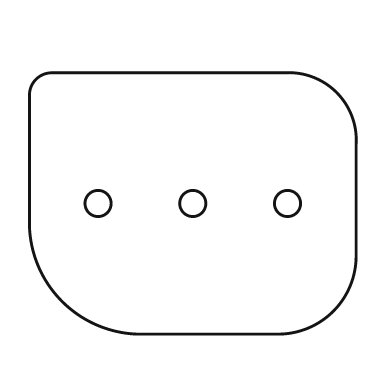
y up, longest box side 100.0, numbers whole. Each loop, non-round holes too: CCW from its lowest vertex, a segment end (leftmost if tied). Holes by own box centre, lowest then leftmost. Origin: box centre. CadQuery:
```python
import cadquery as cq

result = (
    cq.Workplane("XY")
    .moveTo(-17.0, -40.0)
    .lineTo(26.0, -40.0)
    .threePointArc((43.0, -33.0), (50.0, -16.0))
    .lineTo(50.0, 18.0)
    .threePointArc((44.0, 34.0), (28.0, 40.0))
    .lineTo(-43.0, 40.0)
    .threePointArc((-48.0, 38.0), (-50.0, 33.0))
    .lineTo(-50.0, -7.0)
    .threePointArc((-40.0, -30.0), (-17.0, -40.0))
    .close()
    .moveTo(-29.0, 0.0)
    .circle(4.0)
    .moveTo(0.0, 0.0)
    .circle(4.0)
    .moveTo(29.0, 0.0)
    .circle(4.0)
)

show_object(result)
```